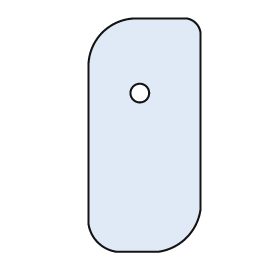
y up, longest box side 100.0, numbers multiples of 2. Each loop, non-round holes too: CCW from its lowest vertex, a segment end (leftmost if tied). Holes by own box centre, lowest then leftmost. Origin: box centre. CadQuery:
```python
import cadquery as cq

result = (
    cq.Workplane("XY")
    .moveTo(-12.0, -50.0)
    .lineTo(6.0, -50.0)
    .threePointArc((18.0, -44.0), (24.0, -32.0))
    .lineTo(24.0, 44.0)
    .threePointArc((22.0, 48.0), (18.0, 50.0))
    .lineTo(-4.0, 50.0)
    .threePointArc((-18.0, 44.0), (-24.0, 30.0))
    .lineTo(-24.0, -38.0)
    .threePointArc((-20.0, -46.0), (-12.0, -50.0))
    .close()
    .moveTo(-2.0, 18.0)
    .circle(4.0)
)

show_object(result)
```